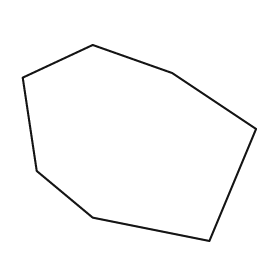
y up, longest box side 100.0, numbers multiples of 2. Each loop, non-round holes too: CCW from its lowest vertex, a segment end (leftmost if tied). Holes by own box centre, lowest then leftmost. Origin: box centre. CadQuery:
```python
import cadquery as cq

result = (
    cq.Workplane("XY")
    .moveTo(30.0, -42.0)
    .lineTo(50.0, 6.0)
    .lineTo(14.0, 30.0)
    .lineTo(-20.0, 42.0)
    .lineTo(-50.0, 28.0)
    .lineTo(-44.0, -12.0)
    .lineTo(-20.0, -32.0)
    .close()
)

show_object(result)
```